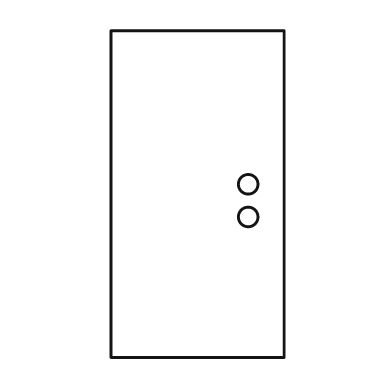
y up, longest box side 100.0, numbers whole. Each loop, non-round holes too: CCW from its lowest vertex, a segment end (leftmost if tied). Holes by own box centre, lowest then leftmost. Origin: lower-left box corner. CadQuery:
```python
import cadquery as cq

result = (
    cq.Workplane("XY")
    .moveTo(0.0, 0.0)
    .lineTo(53.0, 0.0)
    .lineTo(53.0, 100.0)
    .lineTo(0.0, 100.0)
    .close()
    .moveTo(42.0, 43.0)
    .circle(3.0)
    .moveTo(42.0, 53.0)
    .circle(3.0)
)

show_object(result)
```